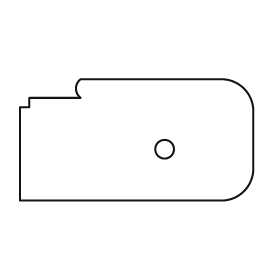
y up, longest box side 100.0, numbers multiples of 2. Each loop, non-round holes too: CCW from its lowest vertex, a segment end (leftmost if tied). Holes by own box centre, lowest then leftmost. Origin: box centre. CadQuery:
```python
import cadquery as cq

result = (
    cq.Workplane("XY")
    .moveTo(-50.0, -26.0)
    .lineTo(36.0, -26.0)
    .threePointArc((46.0, -22.0), (50.0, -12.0))
    .lineTo(50.0, 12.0)
    .threePointArc((46.0, 22.0), (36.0, 26.0))
    .lineTo(-24.0, 26.0)
    .threePointArc((-26.0, 22.0), (-24.0, 18.0))
    .lineTo(-46.0, 18.0)
    .lineTo(-46.0, 14.0)
    .lineTo(-50.0, 14.0)
    .close()
    .moveTo(12.0, -4.0)
    .circle(4.0)
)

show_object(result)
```